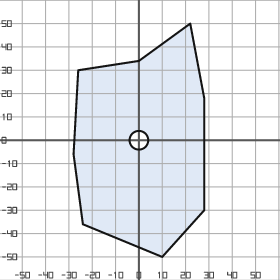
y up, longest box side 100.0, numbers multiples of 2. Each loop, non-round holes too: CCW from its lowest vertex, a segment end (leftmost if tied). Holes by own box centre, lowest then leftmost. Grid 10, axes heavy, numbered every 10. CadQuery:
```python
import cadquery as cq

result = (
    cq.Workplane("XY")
    .moveTo(10.0, -50.0)
    .lineTo(28.0, -30.0)
    .lineTo(28.0, 18.0)
    .lineTo(22.0, 50.0)
    .lineTo(0.0, 34.0)
    .lineTo(-26.0, 30.0)
    .lineTo(-28.0, -6.0)
    .lineTo(-24.0, -36.0)
    .close()
    .moveTo(0.0, 0.0)
    .circle(4.0)
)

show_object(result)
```